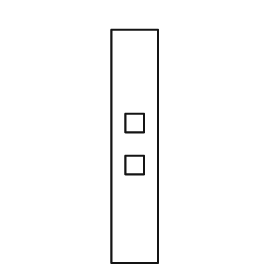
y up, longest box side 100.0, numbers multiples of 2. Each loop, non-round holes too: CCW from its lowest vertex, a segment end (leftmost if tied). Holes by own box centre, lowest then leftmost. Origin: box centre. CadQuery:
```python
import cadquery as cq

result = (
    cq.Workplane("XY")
    .moveTo(-10.0, -50.0)
    .lineTo(10.0, -50.0)
    .lineTo(10.0, 50.0)
    .lineTo(-10.0, 50.0)
    .close()
    .moveTo(-4.0, -12.0)
    .lineTo(4.0, -12.0)
    .lineTo(4.0, -4.0)
    .lineTo(-4.0, -4.0)
    .close()
    .moveTo(-4.0, 6.0)
    .lineTo(4.0, 6.0)
    .lineTo(4.0, 14.0)
    .lineTo(-4.0, 14.0)
    .close()
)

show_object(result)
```